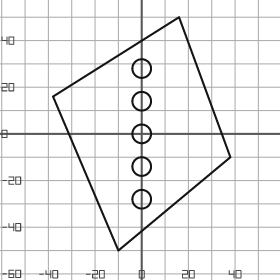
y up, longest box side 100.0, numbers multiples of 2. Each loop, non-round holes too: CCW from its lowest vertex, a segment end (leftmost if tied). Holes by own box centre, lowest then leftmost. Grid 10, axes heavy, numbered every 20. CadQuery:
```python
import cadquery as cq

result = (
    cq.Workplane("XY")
    .moveTo(-10.0, -50.0)
    .lineTo(38.0, -10.0)
    .lineTo(16.0, 50.0)
    .lineTo(-38.0, 16.0)
    .close()
    .moveTo(0.0, -28.0)
    .circle(4.0)
    .moveTo(0.0, -14.0)
    .circle(4.0)
    .moveTo(0.0, 0.0)
    .circle(4.0)
    .moveTo(0.0, 14.0)
    .circle(4.0)
    .moveTo(0.0, 28.0)
    .circle(4.0)
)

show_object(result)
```